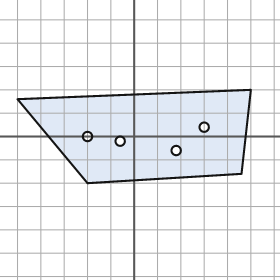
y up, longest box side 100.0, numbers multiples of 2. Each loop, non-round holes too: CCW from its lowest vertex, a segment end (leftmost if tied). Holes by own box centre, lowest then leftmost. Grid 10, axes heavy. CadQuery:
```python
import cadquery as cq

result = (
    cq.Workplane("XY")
    .moveTo(-20.0, -20.0)
    .lineTo(46.0, -16.0)
    .lineTo(50.0, 20.0)
    .lineTo(-50.0, 16.0)
    .close()
    .moveTo(18.0, -6.0)
    .circle(2.0)
    .moveTo(-6.0, -2.0)
    .circle(2.0)
    .moveTo(-20.0, 0.0)
    .circle(2.0)
    .moveTo(30.0, 4.0)
    .circle(2.0)
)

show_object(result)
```